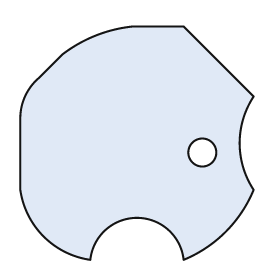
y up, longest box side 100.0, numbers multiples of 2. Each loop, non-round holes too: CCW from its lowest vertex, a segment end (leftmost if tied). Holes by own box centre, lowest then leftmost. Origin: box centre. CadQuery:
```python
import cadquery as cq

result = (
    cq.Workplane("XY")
    .moveTo(-20.0, -50.0)
    .threePointArc((0.0, -32.0), (20.0, -50.0))
    .threePointArc((38.0, -38.0), (50.0, -20.0))
    .threePointArc((44.0, 0.0), (50.0, 20.0))
    .lineTo(20.0, 50.0)
    .lineTo(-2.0, 50.0)
    .threePointArc((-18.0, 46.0), (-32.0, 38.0))
    .lineTo(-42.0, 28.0)
    .threePointArc((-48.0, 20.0), (-50.0, 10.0))
    .lineTo(-50.0, -20.0)
    .threePointArc((-40.0, -40.0), (-20.0, -50.0))
    .close()
    .moveTo(28.0, -4.0)
    .circle(6.0)
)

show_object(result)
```